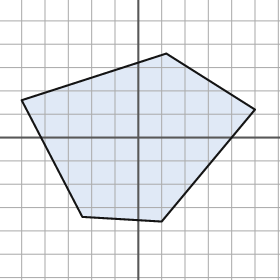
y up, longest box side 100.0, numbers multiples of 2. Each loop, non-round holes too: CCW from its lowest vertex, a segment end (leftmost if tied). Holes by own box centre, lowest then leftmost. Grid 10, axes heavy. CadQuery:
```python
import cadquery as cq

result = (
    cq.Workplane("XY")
    .moveTo(10.0, -36.0)
    .lineTo(50.0, 12.0)
    .lineTo(12.0, 36.0)
    .lineTo(-50.0, 16.0)
    .lineTo(-24.0, -34.0)
    .close()
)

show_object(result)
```